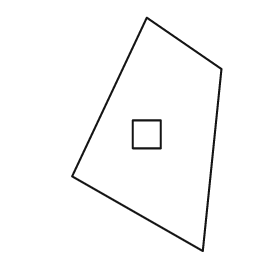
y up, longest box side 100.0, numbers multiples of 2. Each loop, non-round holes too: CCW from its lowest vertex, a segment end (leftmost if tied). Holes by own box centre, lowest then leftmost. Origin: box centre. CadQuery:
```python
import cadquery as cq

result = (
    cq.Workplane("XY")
    .moveTo(24.0, -50.0)
    .lineTo(32.0, 28.0)
    .lineTo(0.0, 50.0)
    .lineTo(-32.0, -18.0)
    .close()
    .moveTo(-6.0, -6.0)
    .lineTo(6.0, -6.0)
    .lineTo(6.0, 6.0)
    .lineTo(-6.0, 6.0)
    .close()
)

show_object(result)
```